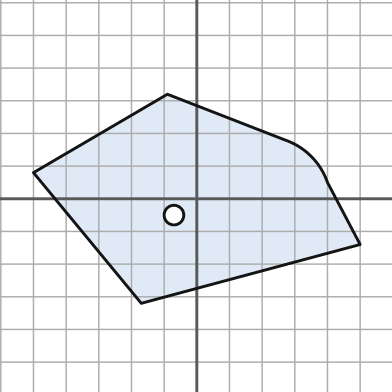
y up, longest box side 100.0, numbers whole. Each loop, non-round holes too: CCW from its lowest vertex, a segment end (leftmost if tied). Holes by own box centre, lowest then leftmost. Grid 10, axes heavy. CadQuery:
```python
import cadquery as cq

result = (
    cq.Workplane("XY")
    .moveTo(-17.0, -32.0)
    .lineTo(50.0, -14.0)
    .lineTo(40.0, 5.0)
    .threePointArc((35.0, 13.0), (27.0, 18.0))
    .lineTo(-9.0, 32.0)
    .lineTo(-50.0, 8.0)
    .close()
    .moveTo(-7.0, -5.0)
    .circle(3.0)
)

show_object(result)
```